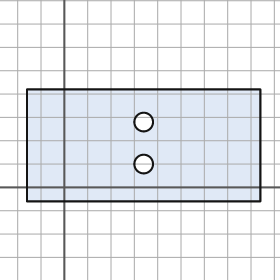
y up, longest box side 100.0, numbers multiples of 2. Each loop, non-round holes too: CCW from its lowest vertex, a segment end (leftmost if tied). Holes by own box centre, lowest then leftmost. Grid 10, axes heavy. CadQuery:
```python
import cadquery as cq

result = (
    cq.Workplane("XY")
    .moveTo(-16.0, -6.0)
    .lineTo(84.0, -6.0)
    .lineTo(84.0, 42.0)
    .lineTo(-16.0, 42.0)
    .close()
    .moveTo(34.0, 10.0)
    .circle(4.0)
    .moveTo(34.0, 28.0)
    .circle(4.0)
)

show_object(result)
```